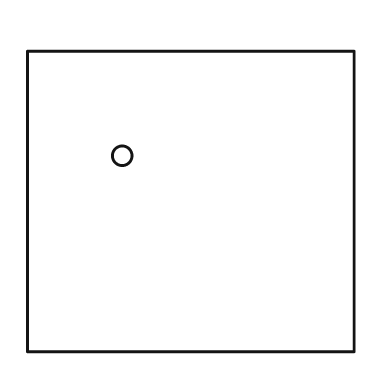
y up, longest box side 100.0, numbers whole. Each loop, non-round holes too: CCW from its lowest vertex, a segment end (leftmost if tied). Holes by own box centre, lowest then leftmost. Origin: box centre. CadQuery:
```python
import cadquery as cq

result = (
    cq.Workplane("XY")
    .moveTo(-50.0, -46.0)
    .lineTo(50.0, -46.0)
    .lineTo(50.0, 46.0)
    .lineTo(-50.0, 46.0)
    .close()
    .moveTo(-21.0, 14.0)
    .circle(3.0)
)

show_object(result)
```